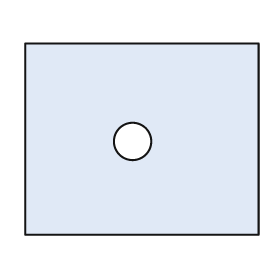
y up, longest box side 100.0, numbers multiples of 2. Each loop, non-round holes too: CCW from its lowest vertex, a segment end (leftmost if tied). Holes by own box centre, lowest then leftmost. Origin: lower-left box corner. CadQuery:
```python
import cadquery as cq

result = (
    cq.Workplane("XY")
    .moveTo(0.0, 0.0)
    .lineTo(100.0, 0.0)
    .lineTo(100.0, 82.0)
    .lineTo(0.0, 82.0)
    .close()
    .moveTo(46.0, 40.0)
    .circle(8.0)
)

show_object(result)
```